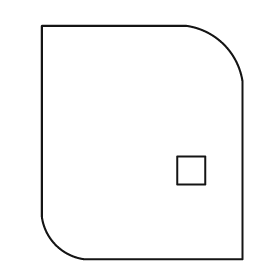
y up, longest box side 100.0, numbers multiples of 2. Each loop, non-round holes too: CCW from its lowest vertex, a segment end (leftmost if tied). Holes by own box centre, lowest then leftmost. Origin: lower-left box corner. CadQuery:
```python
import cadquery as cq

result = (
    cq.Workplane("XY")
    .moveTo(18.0, 0.0)
    .lineTo(86.0, 0.0)
    .lineTo(86.0, 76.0)
    .threePointArc((78.0, 92.0), (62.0, 100.0))
    .lineTo(0.0, 100.0)
    .lineTo(0.0, 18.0)
    .threePointArc((6.0, 6.0), (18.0, 0.0))
    .close()
    .moveTo(58.0, 32.0)
    .lineTo(70.0, 32.0)
    .lineTo(70.0, 44.0)
    .lineTo(58.0, 44.0)
    .close()
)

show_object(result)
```